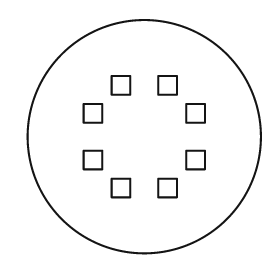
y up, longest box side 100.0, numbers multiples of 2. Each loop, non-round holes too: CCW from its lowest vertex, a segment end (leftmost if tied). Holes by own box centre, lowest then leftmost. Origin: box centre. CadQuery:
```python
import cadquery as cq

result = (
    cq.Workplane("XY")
    .moveTo(0.0, 0.0)
    .circle(50.0)
    .moveTo(-14.0, -26.0)
    .lineTo(-6.0, -26.0)
    .lineTo(-6.0, -18.0)
    .lineTo(-14.0, -18.0)
    .close()
    .moveTo(6.0, -26.0)
    .lineTo(14.0, -26.0)
    .lineTo(14.0, -18.0)
    .lineTo(6.0, -18.0)
    .close()
    .moveTo(-26.0, -14.0)
    .lineTo(-18.0, -14.0)
    .lineTo(-18.0, -6.0)
    .lineTo(-26.0, -6.0)
    .close()
    .moveTo(18.0, -14.0)
    .lineTo(26.0, -14.0)
    .lineTo(26.0, -6.0)
    .lineTo(18.0, -6.0)
    .close()
    .moveTo(-26.0, 6.0)
    .lineTo(-18.0, 6.0)
    .lineTo(-18.0, 14.0)
    .lineTo(-26.0, 14.0)
    .close()
    .moveTo(18.0, 6.0)
    .lineTo(26.0, 6.0)
    .lineTo(26.0, 14.0)
    .lineTo(18.0, 14.0)
    .close()
    .moveTo(-14.0, 18.0)
    .lineTo(-6.0, 18.0)
    .lineTo(-6.0, 26.0)
    .lineTo(-14.0, 26.0)
    .close()
    .moveTo(6.0, 18.0)
    .lineTo(14.0, 18.0)
    .lineTo(14.0, 26.0)
    .lineTo(6.0, 26.0)
    .close()
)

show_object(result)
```